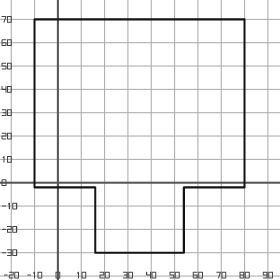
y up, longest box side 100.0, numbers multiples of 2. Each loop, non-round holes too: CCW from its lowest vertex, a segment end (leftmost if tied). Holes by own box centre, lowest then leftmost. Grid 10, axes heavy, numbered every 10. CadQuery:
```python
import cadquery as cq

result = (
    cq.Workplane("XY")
    .moveTo(16.0, -30.0)
    .lineTo(54.0, -30.0)
    .lineTo(54.0, -2.0)
    .lineTo(80.0, -2.0)
    .lineTo(80.0, 70.0)
    .lineTo(-10.0, 70.0)
    .lineTo(-10.0, -2.0)
    .lineTo(16.0, -2.0)
    .close()
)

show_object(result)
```